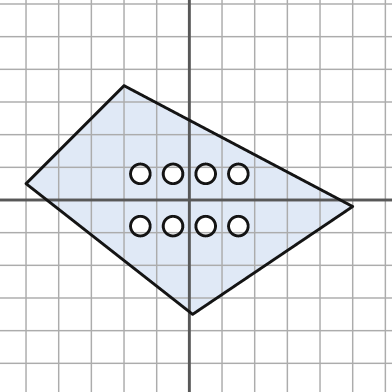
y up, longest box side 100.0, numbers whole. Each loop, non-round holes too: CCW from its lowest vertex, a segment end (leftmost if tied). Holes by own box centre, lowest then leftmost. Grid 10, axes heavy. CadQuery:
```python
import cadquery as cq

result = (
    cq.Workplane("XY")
    .moveTo(1.0, -35.0)
    .lineTo(50.0, -2.0)
    .lineTo(-20.0, 35.0)
    .lineTo(-50.0, 5.0)
    .close()
    .moveTo(-15.0, -8.0)
    .circle(3.0)
    .moveTo(-5.0, -8.0)
    .circle(3.0)
    .moveTo(5.0, -8.0)
    .circle(3.0)
    .moveTo(15.0, -8.0)
    .circle(3.0)
    .moveTo(-15.0, 8.0)
    .circle(3.0)
    .moveTo(-5.0, 8.0)
    .circle(3.0)
    .moveTo(5.0, 8.0)
    .circle(3.0)
    .moveTo(15.0, 8.0)
    .circle(3.0)
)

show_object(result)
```